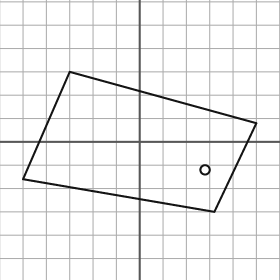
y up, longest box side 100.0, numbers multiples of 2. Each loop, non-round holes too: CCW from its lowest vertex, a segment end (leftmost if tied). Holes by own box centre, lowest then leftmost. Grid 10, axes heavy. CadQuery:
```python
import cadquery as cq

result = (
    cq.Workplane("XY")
    .moveTo(32.0, -30.0)
    .lineTo(50.0, 8.0)
    .lineTo(-30.0, 30.0)
    .lineTo(-50.0, -16.0)
    .close()
    .moveTo(28.0, -12.0)
    .circle(2.0)
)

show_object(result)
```